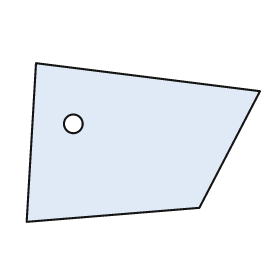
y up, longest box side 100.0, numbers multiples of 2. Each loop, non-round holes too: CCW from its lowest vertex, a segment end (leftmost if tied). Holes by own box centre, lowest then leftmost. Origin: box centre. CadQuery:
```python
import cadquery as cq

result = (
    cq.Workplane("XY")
    .moveTo(-50.0, -34.0)
    .lineTo(24.0, -28.0)
    .lineTo(50.0, 22.0)
    .lineTo(-46.0, 34.0)
    .close()
    .moveTo(-30.0, 8.0)
    .circle(4.0)
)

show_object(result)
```